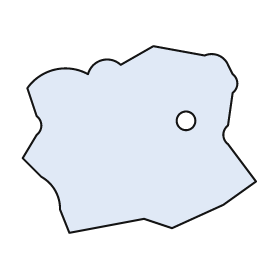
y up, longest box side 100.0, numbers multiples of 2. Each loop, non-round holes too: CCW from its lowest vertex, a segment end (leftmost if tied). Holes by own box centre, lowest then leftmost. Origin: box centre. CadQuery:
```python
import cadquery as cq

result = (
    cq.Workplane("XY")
    .moveTo(-30.0, -40.0)
    .lineTo(2.0, -34.0)
    .lineTo(14.0, -38.0)
    .lineTo(36.0, -28.0)
    .lineTo(50.0, -18.0)
    .lineTo(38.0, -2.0)
    .threePointArc((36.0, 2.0), (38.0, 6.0))
    .lineTo(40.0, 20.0)
    .threePointArc((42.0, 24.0), (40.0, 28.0))
    .lineTo(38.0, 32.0)
    .threePointArc((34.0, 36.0), (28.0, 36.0))
    .lineTo(6.0, 40.0)
    .lineTo(-8.0, 32.0)
    .threePointArc((-16.0, 34.0), (-22.0, 28.0))
    .threePointArc((-36.0, 30.0), (-48.0, 22.0))
    .lineTo(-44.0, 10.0)
    .threePointArc((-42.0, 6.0), (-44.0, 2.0))
    .lineTo(-50.0, -8.0)
    .lineTo(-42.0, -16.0)
    .threePointArc((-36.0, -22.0), (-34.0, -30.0))
    .close()
    .moveTo(20.0, 8.0)
    .circle(4.0)
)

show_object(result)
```